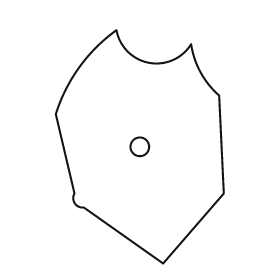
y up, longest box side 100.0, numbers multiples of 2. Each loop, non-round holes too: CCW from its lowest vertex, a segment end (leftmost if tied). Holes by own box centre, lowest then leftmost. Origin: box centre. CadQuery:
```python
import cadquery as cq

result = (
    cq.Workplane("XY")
    .moveTo(10.0, -50.0)
    .lineTo(36.0, -20.0)
    .lineTo(34.0, 22.0)
    .threePointArc((26.0, 32.0), (22.0, 44.0))
    .threePointArc((4.0, 36.0), (-10.0, 50.0))
    .threePointArc((-26.0, 34.0), (-36.0, 14.0))
    .lineTo(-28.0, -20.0)
    .threePointArc((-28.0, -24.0), (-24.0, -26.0))
    .close()
    .moveTo(0.0, 0.0)
    .circle(4.0)
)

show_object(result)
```